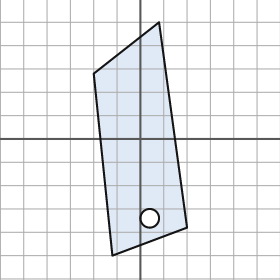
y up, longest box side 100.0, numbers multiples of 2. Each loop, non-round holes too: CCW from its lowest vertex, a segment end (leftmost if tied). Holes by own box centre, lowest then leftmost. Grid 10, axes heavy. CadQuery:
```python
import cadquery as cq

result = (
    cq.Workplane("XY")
    .moveTo(-12.0, -50.0)
    .lineTo(20.0, -38.0)
    .lineTo(8.0, 50.0)
    .lineTo(-20.0, 28.0)
    .close()
    .moveTo(4.0, -34.0)
    .circle(4.0)
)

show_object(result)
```